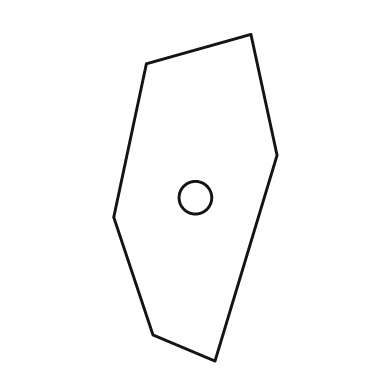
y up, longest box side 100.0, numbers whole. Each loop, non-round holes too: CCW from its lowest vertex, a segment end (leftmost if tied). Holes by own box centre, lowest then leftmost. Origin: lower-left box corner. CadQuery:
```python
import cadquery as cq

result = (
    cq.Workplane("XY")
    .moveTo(31.0, 0.0)
    .lineTo(50.0, 63.0)
    .lineTo(42.0, 100.0)
    .lineTo(10.0, 91.0)
    .lineTo(0.0, 44.0)
    .lineTo(12.0, 8.0)
    .close()
    .moveTo(25.0, 50.0)
    .circle(5.0)
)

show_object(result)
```